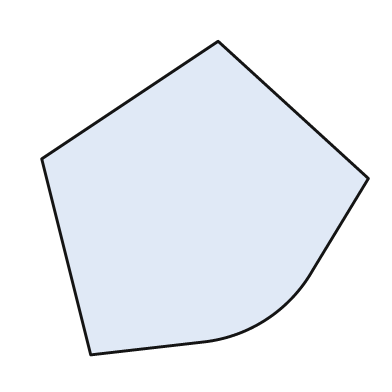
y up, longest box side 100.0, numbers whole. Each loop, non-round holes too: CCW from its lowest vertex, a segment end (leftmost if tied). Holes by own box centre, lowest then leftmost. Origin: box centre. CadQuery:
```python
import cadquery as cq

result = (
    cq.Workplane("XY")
    .moveTo(-35.0, -48.0)
    .lineTo(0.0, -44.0)
    .threePointArc((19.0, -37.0), (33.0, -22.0))
    .lineTo(50.0, 6.0)
    .lineTo(4.0, 48.0)
    .lineTo(-50.0, 12.0)
    .close()
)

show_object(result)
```